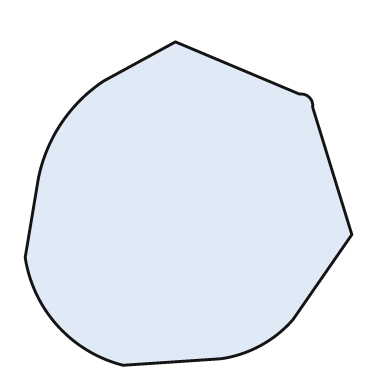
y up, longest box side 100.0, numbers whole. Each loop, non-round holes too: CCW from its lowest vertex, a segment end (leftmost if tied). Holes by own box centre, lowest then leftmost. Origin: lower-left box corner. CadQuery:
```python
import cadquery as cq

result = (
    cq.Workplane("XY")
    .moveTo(30.0, 0.0)
    .lineTo(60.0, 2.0)
    .threePointArc((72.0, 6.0), (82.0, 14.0))
    .lineTo(100.0, 40.0)
    .lineTo(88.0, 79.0)
    .threePointArc((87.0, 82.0), (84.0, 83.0))
    .lineTo(46.0, 99.0)
    .lineTo(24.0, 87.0)
    .threePointArc((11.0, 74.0), (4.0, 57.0))
    .lineTo(0.0, 33.0)
    .threePointArc((10.0, 12.0), (30.0, 0.0))
    .close()
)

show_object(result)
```